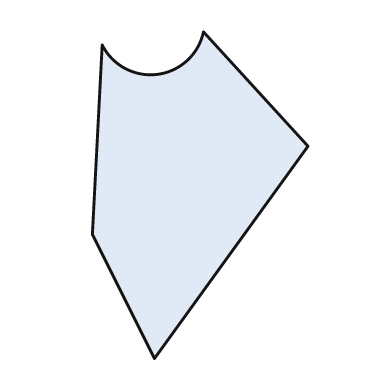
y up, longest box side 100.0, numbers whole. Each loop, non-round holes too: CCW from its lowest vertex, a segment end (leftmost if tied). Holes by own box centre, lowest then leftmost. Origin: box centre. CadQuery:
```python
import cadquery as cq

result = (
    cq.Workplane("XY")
    .moveTo(-14.0, -50.0)
    .lineTo(33.0, 15.0)
    .lineTo(1.0, 50.0)
    .threePointArc((-13.0, 37.0), (-30.0, 46.0))
    .lineTo(-33.0, -12.0)
    .close()
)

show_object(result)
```